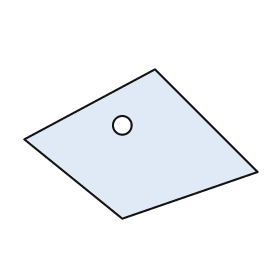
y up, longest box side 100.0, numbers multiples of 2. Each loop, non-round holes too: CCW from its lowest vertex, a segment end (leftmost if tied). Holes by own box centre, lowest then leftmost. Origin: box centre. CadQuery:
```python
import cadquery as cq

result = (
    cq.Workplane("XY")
    .moveTo(-8.0, -32.0)
    .lineTo(50.0, -12.0)
    .lineTo(6.0, 32.0)
    .lineTo(-50.0, 2.0)
    .close()
    .moveTo(-8.0, 8.0)
    .circle(4.0)
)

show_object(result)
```